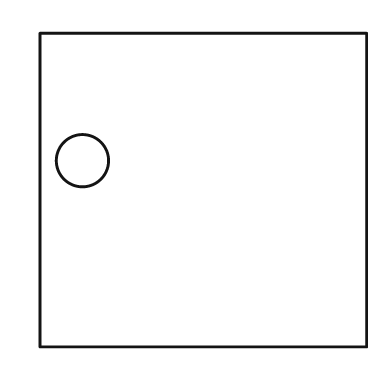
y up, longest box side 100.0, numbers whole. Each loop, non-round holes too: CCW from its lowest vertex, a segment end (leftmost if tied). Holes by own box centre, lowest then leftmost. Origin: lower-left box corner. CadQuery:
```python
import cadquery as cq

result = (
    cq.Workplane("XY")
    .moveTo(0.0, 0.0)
    .lineTo(100.0, 0.0)
    .lineTo(100.0, 96.0)
    .lineTo(0.0, 96.0)
    .close()
    .moveTo(13.0, 57.0)
    .circle(8.0)
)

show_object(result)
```